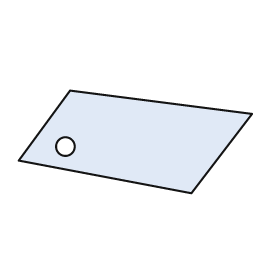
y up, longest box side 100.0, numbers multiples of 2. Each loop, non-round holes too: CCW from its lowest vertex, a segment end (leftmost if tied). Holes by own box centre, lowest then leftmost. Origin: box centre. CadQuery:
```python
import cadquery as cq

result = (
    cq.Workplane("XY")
    .moveTo(24.0, -22.0)
    .lineTo(50.0, 12.0)
    .lineTo(-28.0, 22.0)
    .lineTo(-50.0, -8.0)
    .close()
    .moveTo(-30.0, -2.0)
    .circle(4.0)
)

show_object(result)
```